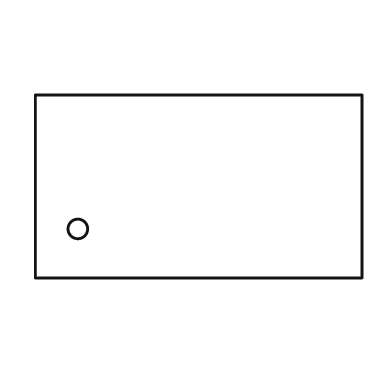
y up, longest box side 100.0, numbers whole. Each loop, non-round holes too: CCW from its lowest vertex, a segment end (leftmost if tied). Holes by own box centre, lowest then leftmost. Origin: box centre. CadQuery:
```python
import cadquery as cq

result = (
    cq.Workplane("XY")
    .moveTo(-50.0, -28.0)
    .lineTo(50.0, -28.0)
    .lineTo(50.0, 28.0)
    .lineTo(-50.0, 28.0)
    .close()
    .moveTo(-37.0, -13.0)
    .circle(3.0)
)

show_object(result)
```